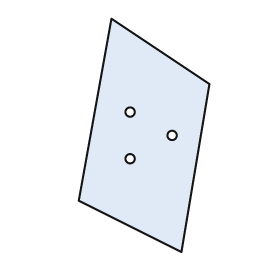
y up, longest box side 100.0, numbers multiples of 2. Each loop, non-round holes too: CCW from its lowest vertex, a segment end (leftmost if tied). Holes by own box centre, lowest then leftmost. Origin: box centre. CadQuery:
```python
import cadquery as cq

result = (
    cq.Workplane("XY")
    .moveTo(16.0, -50.0)
    .lineTo(28.0, 22.0)
    .lineTo(-14.0, 50.0)
    .lineTo(-28.0, -28.0)
    .close()
    .moveTo(-6.0, -10.0)
    .circle(2.0)
    .moveTo(12.0, 0.0)
    .circle(2.0)
    .moveTo(-6.0, 10.0)
    .circle(2.0)
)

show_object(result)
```